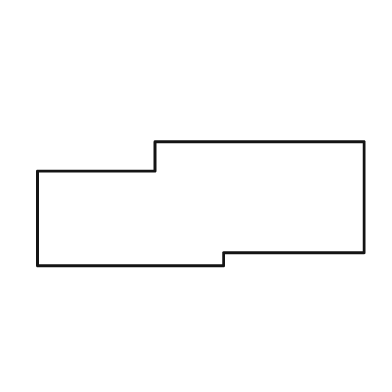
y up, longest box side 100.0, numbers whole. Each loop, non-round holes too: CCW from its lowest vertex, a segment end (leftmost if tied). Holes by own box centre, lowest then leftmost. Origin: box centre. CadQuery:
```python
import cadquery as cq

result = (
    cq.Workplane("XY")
    .moveTo(-50.0, -19.0)
    .lineTo(7.0, -19.0)
    .lineTo(7.0, -15.0)
    .lineTo(50.0, -15.0)
    .lineTo(50.0, 19.0)
    .lineTo(-14.0, 19.0)
    .lineTo(-14.0, 10.0)
    .lineTo(-50.0, 10.0)
    .close()
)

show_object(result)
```